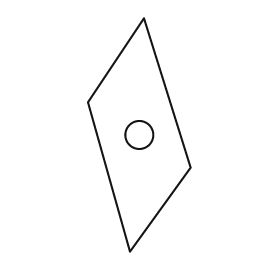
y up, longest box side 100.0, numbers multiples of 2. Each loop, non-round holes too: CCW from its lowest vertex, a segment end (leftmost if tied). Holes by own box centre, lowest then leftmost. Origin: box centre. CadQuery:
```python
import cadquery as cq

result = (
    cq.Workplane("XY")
    .moveTo(-4.0, -50.0)
    .lineTo(22.0, -14.0)
    .lineTo(2.0, 50.0)
    .lineTo(-22.0, 14.0)
    .close()
    .moveTo(0.0, 0.0)
    .circle(6.0)
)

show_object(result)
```